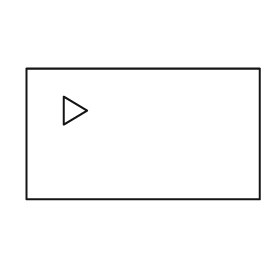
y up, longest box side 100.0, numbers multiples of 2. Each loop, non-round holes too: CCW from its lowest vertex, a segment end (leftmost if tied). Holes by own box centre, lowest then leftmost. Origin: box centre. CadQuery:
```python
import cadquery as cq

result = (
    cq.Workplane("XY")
    .moveTo(-50.0, -28.0)
    .lineTo(50.0, -28.0)
    .lineTo(50.0, 28.0)
    .lineTo(-50.0, 28.0)
    .close()
    .moveTo(-34.0, 4.0)
    .lineTo(-24.0, 10.0)
    .lineTo(-34.0, 16.0)
    .close()
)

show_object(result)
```